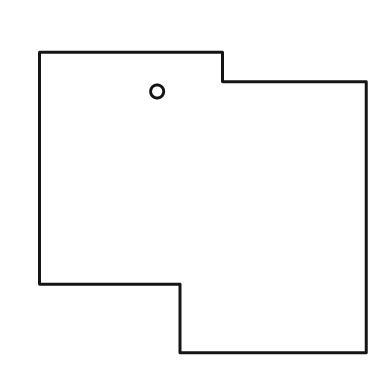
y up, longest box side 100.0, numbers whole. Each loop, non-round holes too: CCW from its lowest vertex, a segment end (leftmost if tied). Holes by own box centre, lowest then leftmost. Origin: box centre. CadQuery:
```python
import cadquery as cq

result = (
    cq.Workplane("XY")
    .moveTo(-7.0, -46.0)
    .lineTo(50.0, -46.0)
    .lineTo(50.0, 37.0)
    .lineTo(6.0, 37.0)
    .lineTo(6.0, 46.0)
    .lineTo(-50.0, 46.0)
    .lineTo(-50.0, -25.0)
    .lineTo(-7.0, -25.0)
    .close()
    .moveTo(-14.0, 34.0)
    .circle(2.0)
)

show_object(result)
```